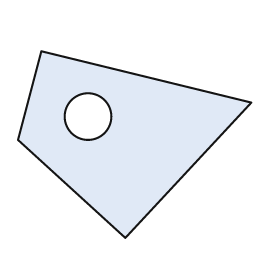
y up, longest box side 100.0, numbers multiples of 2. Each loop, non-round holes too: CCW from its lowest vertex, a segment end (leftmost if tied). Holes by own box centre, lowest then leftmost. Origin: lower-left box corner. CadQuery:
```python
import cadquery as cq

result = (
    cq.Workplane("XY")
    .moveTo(46.0, 0.0)
    .lineTo(100.0, 58.0)
    .lineTo(10.0, 80.0)
    .lineTo(0.0, 42.0)
    .close()
    .moveTo(30.0, 52.0)
    .circle(10.0)
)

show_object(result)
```